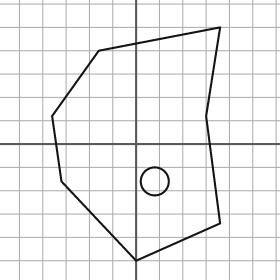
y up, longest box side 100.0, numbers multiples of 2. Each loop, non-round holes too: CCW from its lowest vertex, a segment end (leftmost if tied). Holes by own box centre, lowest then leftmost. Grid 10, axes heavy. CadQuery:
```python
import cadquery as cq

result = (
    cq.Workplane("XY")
    .moveTo(0.0, -50.0)
    .lineTo(36.0, -34.0)
    .lineTo(30.0, 12.0)
    .lineTo(36.0, 50.0)
    .lineTo(-16.0, 40.0)
    .lineTo(-36.0, 12.0)
    .lineTo(-32.0, -16.0)
    .close()
    .moveTo(8.0, -16.0)
    .circle(6.0)
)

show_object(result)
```